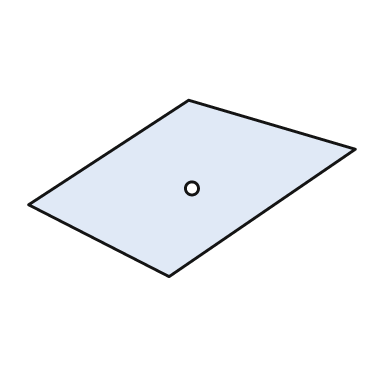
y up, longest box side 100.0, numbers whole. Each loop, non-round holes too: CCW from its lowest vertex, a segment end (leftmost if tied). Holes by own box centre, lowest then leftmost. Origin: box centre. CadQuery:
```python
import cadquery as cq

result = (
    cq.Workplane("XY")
    .moveTo(-7.0, -27.0)
    .lineTo(50.0, 12.0)
    .lineTo(-1.0, 27.0)
    .lineTo(-50.0, -5.0)
    .close()
    .moveTo(0.0, 0.0)
    .circle(2.0)
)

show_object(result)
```